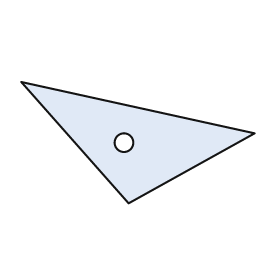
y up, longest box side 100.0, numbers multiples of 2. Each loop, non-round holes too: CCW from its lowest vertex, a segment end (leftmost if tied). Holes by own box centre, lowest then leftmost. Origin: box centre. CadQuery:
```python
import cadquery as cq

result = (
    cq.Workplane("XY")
    .moveTo(-4.0, -26.0)
    .lineTo(50.0, 4.0)
    .lineTo(-50.0, 26.0)
    .close()
    .moveTo(-6.0, 0.0)
    .circle(4.0)
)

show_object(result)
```